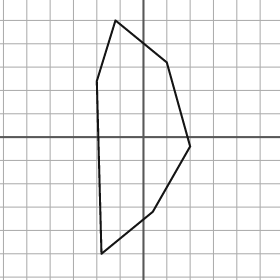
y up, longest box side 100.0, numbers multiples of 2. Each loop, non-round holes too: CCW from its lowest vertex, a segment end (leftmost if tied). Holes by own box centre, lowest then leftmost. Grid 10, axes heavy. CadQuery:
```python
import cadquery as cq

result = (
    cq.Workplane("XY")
    .moveTo(-18.0, -50.0)
    .lineTo(4.0, -32.0)
    .lineTo(20.0, -4.0)
    .lineTo(10.0, 32.0)
    .lineTo(-12.0, 50.0)
    .lineTo(-20.0, 24.0)
    .close()
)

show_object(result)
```